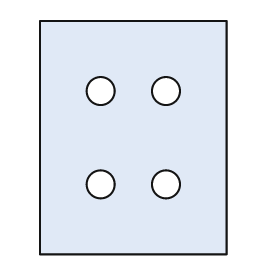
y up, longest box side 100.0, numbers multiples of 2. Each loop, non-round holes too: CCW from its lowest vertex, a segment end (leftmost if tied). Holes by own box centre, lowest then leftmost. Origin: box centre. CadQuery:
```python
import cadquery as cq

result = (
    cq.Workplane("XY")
    .moveTo(-40.0, -50.0)
    .lineTo(40.0, -50.0)
    .lineTo(40.0, 50.0)
    .lineTo(-40.0, 50.0)
    .close()
    .moveTo(-14.0, -20.0)
    .circle(6.0)
    .moveTo(14.0, -20.0)
    .circle(6.0)
    .moveTo(-14.0, 20.0)
    .circle(6.0)
    .moveTo(14.0, 20.0)
    .circle(6.0)
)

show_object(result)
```